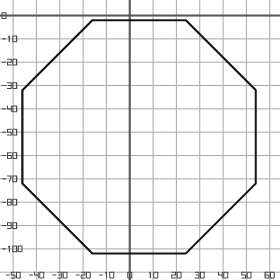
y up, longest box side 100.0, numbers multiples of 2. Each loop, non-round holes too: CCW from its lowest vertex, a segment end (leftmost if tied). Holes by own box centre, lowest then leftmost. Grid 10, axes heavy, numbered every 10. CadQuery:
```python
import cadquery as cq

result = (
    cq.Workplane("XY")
    .moveTo(-16.0, -102.0)
    .lineTo(24.0, -102.0)
    .lineTo(54.0, -72.0)
    .lineTo(54.0, -32.0)
    .lineTo(24.0, -2.0)
    .lineTo(-16.0, -2.0)
    .lineTo(-46.0, -32.0)
    .lineTo(-46.0, -72.0)
    .close()
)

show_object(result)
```